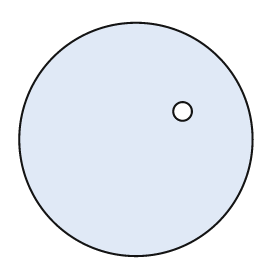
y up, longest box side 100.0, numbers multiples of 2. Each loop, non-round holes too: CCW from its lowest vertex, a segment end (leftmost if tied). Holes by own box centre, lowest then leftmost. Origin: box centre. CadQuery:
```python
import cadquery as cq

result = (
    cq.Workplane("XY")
    .moveTo(0.0, 0.0)
    .circle(50.0)
    .moveTo(20.0, 12.0)
    .circle(4.0)
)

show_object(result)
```